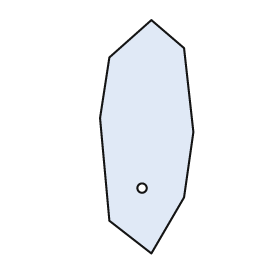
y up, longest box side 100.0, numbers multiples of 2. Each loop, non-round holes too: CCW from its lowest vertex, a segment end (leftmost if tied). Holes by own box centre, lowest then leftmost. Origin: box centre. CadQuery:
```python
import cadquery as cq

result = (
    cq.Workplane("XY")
    .moveTo(2.0, -50.0)
    .lineTo(16.0, -26.0)
    .lineTo(20.0, 2.0)
    .lineTo(16.0, 38.0)
    .lineTo(2.0, 50.0)
    .lineTo(-16.0, 34.0)
    .lineTo(-20.0, 8.0)
    .lineTo(-16.0, -36.0)
    .close()
    .moveTo(-2.0, -22.0)
    .circle(2.0)
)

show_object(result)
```